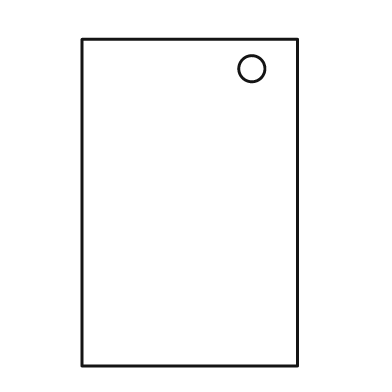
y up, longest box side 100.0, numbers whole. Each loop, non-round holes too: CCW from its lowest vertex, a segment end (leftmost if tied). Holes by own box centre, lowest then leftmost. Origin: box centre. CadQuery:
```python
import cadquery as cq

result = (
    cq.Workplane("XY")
    .moveTo(-33.0, -50.0)
    .lineTo(33.0, -50.0)
    .lineTo(33.0, 50.0)
    .lineTo(-33.0, 50.0)
    .close()
    .moveTo(19.0, 41.0)
    .circle(4.0)
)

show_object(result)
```